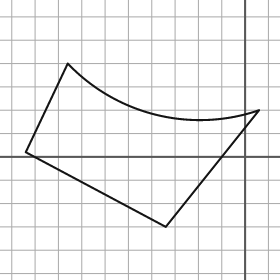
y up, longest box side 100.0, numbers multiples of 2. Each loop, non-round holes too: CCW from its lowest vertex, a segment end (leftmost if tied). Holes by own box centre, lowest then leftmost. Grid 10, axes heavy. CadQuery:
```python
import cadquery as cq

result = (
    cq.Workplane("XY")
    .moveTo(-34.0, -30.0)
    .lineTo(6.0, 20.0)
    .threePointArc((-38.0, 18.0), (-76.0, 40.0))
    .lineTo(-94.0, 2.0)
    .close()
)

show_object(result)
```